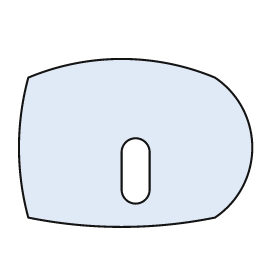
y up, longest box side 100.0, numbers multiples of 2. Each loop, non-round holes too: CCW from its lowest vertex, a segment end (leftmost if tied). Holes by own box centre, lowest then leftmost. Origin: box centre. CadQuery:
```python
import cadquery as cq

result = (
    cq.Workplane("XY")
    .moveTo(-46.0, -32.0)
    .threePointArc((-6.0, -36.0), (34.0, -32.0))
    .threePointArc((50.0, -2.0), (34.0, 28.0))
    .threePointArc((-6.0, 36.0), (-46.0, 28.0))
    .threePointArc((-50.0, -2.0), (-46.0, -32.0))
    .close()
    .moveTo(-6.0, -20.0)
    .threePointArc((0.0, -26.0), (6.0, -20.0))
    .lineTo(6.0, -4.0)
    .threePointArc((0.0, 2.0), (-6.0, -4.0))
    .close()
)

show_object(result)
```